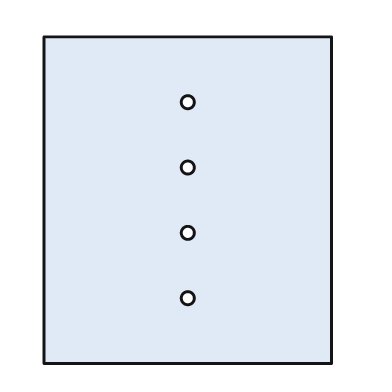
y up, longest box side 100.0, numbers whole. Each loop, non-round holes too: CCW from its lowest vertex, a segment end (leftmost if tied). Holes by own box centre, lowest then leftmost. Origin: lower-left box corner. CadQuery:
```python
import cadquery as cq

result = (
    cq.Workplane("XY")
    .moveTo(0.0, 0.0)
    .lineTo(88.0, 0.0)
    .lineTo(88.0, 100.0)
    .lineTo(0.0, 100.0)
    .close()
    .moveTo(44.0, 20.0)
    .circle(2.0)
    .moveTo(44.0, 40.0)
    .circle(2.0)
    .moveTo(44.0, 60.0)
    .circle(2.0)
    .moveTo(44.0, 80.0)
    .circle(2.0)
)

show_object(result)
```